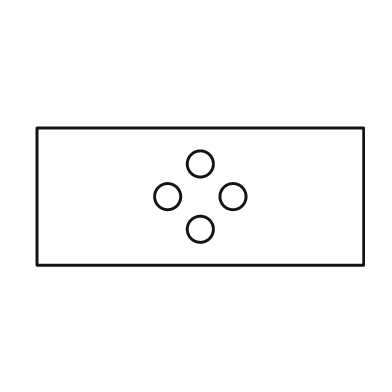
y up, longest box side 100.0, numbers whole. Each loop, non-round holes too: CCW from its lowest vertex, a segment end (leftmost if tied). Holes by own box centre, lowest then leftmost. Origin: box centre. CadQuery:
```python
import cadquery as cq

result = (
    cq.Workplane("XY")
    .moveTo(-50.0, -21.0)
    .lineTo(50.0, -21.0)
    .lineTo(50.0, 21.0)
    .lineTo(-50.0, 21.0)
    .close()
    .moveTo(0.0, -10.0)
    .circle(4.0)
    .moveTo(-10.0, 0.0)
    .circle(4.0)
    .moveTo(10.0, 0.0)
    .circle(4.0)
    .moveTo(0.0, 10.0)
    .circle(4.0)
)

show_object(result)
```